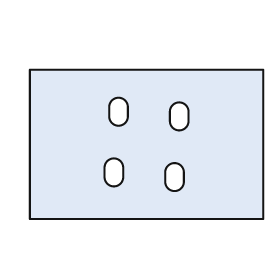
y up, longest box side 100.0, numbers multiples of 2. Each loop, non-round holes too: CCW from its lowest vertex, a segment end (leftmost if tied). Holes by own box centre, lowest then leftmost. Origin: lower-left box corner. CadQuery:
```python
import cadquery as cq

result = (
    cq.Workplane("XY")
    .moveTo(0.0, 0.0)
    .lineTo(100.0, 0.0)
    .lineTo(100.0, 64.0)
    .lineTo(0.0, 64.0)
    .close()
    .moveTo(58.0, 16.0)
    .threePointArc((62.0, 12.0), (66.0, 16.0))
    .lineTo(66.0, 20.0)
    .threePointArc((62.0, 24.0), (58.0, 20.0))
    .close()
    .moveTo(32.0, 18.0)
    .threePointArc((36.0, 14.0), (40.0, 18.0))
    .lineTo(40.0, 22.0)
    .threePointArc((36.0, 26.0), (32.0, 22.0))
    .close()
    .moveTo(60.0, 42.0)
    .threePointArc((64.0, 38.0), (68.0, 42.0))
    .lineTo(68.0, 46.0)
    .threePointArc((64.0, 50.0), (60.0, 46.0))
    .close()
    .moveTo(34.0, 44.0)
    .threePointArc((38.0, 40.0), (42.0, 44.0))
    .lineTo(42.0, 48.0)
    .threePointArc((38.0, 52.0), (34.0, 48.0))
    .close()
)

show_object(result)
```